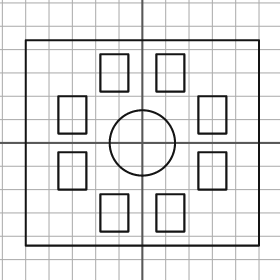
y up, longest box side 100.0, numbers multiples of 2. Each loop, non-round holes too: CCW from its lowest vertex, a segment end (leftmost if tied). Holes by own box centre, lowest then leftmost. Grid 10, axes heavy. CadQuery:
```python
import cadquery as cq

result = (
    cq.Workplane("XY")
    .moveTo(-50.0, -44.0)
    .lineTo(50.0, -44.0)
    .lineTo(50.0, 44.0)
    .lineTo(-50.0, 44.0)
    .close()
    .moveTo(-18.0, -38.0)
    .lineTo(-6.0, -38.0)
    .lineTo(-6.0, -22.0)
    .lineTo(-18.0, -22.0)
    .close()
    .moveTo(6.0, -38.0)
    .lineTo(18.0, -38.0)
    .lineTo(18.0, -22.0)
    .lineTo(6.0, -22.0)
    .close()
    .moveTo(-36.0, -20.0)
    .lineTo(-24.0, -20.0)
    .lineTo(-24.0, -4.0)
    .lineTo(-36.0, -4.0)
    .close()
    .moveTo(24.0, -20.0)
    .lineTo(36.0, -20.0)
    .lineTo(36.0, -4.0)
    .lineTo(24.0, -4.0)
    .close()
    .moveTo(0.0, 0.0)
    .circle(14.0)
    .moveTo(-36.0, 4.0)
    .lineTo(-24.0, 4.0)
    .lineTo(-24.0, 20.0)
    .lineTo(-36.0, 20.0)
    .close()
    .moveTo(24.0, 4.0)
    .lineTo(36.0, 4.0)
    .lineTo(36.0, 20.0)
    .lineTo(24.0, 20.0)
    .close()
    .moveTo(-18.0, 22.0)
    .lineTo(-6.0, 22.0)
    .lineTo(-6.0, 38.0)
    .lineTo(-18.0, 38.0)
    .close()
    .moveTo(6.0, 22.0)
    .lineTo(18.0, 22.0)
    .lineTo(18.0, 38.0)
    .lineTo(6.0, 38.0)
    .close()
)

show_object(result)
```